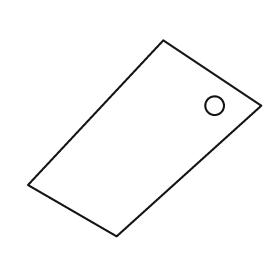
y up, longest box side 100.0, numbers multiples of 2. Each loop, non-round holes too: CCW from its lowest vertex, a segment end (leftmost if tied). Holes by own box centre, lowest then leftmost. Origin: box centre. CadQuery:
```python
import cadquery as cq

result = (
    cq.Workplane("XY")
    .moveTo(-12.0, -42.0)
    .lineTo(50.0, 14.0)
    .lineTo(8.0, 42.0)
    .lineTo(-50.0, -20.0)
    .close()
    .moveTo(30.0, 14.0)
    .circle(4.0)
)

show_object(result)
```